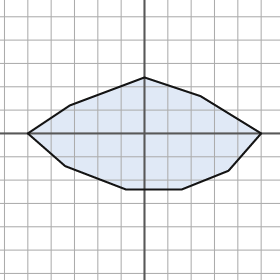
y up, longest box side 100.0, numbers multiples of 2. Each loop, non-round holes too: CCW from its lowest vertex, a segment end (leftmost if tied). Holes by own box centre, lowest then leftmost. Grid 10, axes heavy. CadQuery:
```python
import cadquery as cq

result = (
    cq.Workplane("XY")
    .moveTo(-8.0, -24.0)
    .lineTo(16.0, -24.0)
    .lineTo(36.0, -16.0)
    .lineTo(50.0, 0.0)
    .lineTo(24.0, 16.0)
    .lineTo(0.0, 24.0)
    .lineTo(-32.0, 12.0)
    .lineTo(-50.0, 0.0)
    .lineTo(-34.0, -14.0)
    .close()
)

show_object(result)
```